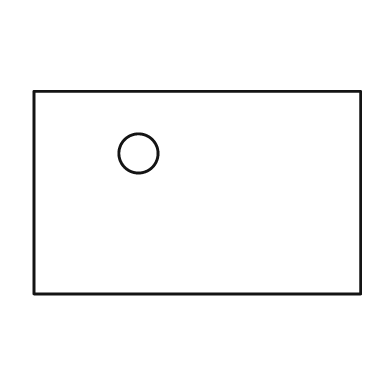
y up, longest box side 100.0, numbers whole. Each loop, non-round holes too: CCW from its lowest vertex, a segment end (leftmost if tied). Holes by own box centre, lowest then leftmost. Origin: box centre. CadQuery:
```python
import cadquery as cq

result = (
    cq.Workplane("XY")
    .moveTo(-50.0, -31.0)
    .lineTo(50.0, -31.0)
    .lineTo(50.0, 31.0)
    .lineTo(-50.0, 31.0)
    .close()
    .moveTo(-18.0, 12.0)
    .circle(6.0)
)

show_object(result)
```